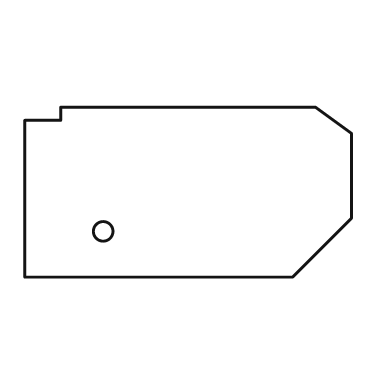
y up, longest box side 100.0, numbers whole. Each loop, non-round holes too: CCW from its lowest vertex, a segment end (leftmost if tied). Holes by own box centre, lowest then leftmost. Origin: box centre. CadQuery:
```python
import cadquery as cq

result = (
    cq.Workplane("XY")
    .moveTo(-50.0, -26.0)
    .lineTo(32.0, -26.0)
    .lineTo(50.0, -8.0)
    .lineTo(50.0, 18.0)
    .lineTo(39.0, 26.0)
    .lineTo(-39.0, 26.0)
    .lineTo(-39.0, 22.0)
    .lineTo(-50.0, 22.0)
    .close()
    .moveTo(-26.0, -12.0)
    .circle(3.0)
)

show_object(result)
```